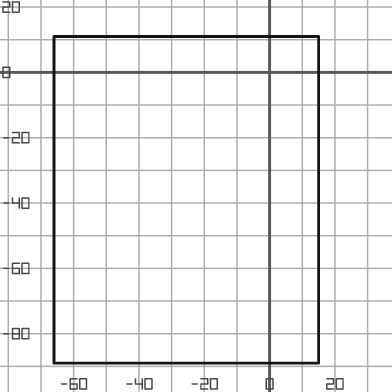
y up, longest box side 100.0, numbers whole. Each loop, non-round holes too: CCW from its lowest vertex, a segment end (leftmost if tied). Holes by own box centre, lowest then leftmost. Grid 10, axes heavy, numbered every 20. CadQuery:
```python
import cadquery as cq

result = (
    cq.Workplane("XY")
    .moveTo(-66.0, -89.0)
    .lineTo(15.0, -89.0)
    .lineTo(15.0, 11.0)
    .lineTo(-66.0, 11.0)
    .close()
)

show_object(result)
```